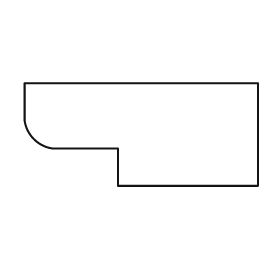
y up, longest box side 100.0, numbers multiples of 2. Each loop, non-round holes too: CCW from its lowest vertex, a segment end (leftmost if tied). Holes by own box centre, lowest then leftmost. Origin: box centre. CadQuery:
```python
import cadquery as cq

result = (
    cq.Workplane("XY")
    .moveTo(-10.0, -22.0)
    .lineTo(50.0, -22.0)
    .lineTo(50.0, 22.0)
    .lineTo(-50.0, 22.0)
    .lineTo(-50.0, 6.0)
    .threePointArc((-46.0, -2.0), (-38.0, -6.0))
    .lineTo(-10.0, -6.0)
    .close()
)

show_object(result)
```